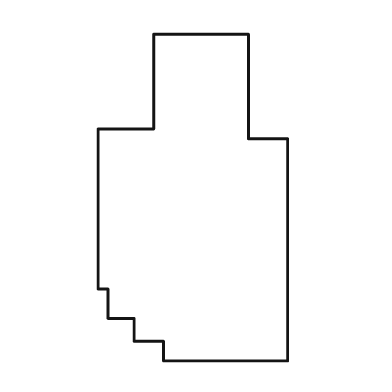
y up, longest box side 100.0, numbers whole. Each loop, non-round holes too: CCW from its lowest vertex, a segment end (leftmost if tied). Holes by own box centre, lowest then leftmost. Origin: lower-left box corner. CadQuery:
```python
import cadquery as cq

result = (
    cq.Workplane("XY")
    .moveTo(20.0, 0.0)
    .lineTo(58.0, 0.0)
    .lineTo(58.0, 68.0)
    .lineTo(46.0, 68.0)
    .lineTo(46.0, 100.0)
    .lineTo(17.0, 100.0)
    .lineTo(17.0, 71.0)
    .lineTo(0.0, 71.0)
    .lineTo(0.0, 22.0)
    .lineTo(3.0, 22.0)
    .lineTo(3.0, 13.0)
    .lineTo(11.0, 13.0)
    .lineTo(11.0, 6.0)
    .lineTo(20.0, 6.0)
    .close()
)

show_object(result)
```